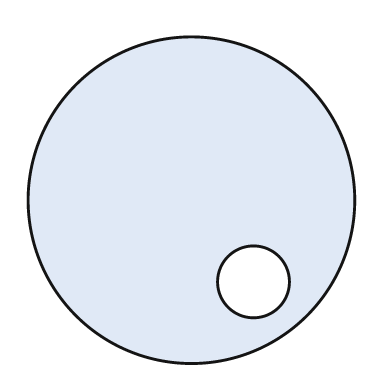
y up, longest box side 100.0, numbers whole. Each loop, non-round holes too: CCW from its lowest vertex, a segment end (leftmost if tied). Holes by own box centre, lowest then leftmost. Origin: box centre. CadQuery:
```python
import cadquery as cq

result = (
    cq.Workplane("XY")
    .moveTo(0.0, 0.0)
    .circle(50.0)
    .moveTo(19.0, -25.0)
    .circle(11.0)
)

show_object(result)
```